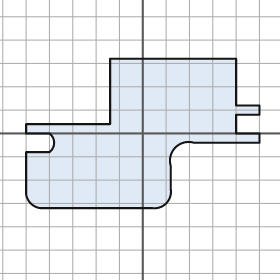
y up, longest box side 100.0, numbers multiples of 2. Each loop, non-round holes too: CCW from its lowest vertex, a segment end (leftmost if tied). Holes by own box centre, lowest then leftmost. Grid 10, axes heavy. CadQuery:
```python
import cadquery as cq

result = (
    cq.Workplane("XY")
    .moveTo(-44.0, -32.0)
    .lineTo(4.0, -32.0)
    .threePointArc((10.0, -30.0), (12.0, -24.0))
    .lineTo(12.0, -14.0)
    .threePointArc((14.0, -6.0), (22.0, -4.0))
    .lineTo(50.0, -4.0)
    .lineTo(50.0, 0.0)
    .lineTo(40.0, 0.0)
    .lineTo(40.0, 8.0)
    .lineTo(50.0, 8.0)
    .lineTo(50.0, 12.0)
    .lineTo(40.0, 12.0)
    .lineTo(40.0, 32.0)
    .lineTo(-14.0, 32.0)
    .lineTo(-14.0, 4.0)
    .lineTo(-50.0, 4.0)
    .lineTo(-50.0, 0.0)
    .lineTo(-40.0, 0.0)
    .threePointArc((-38.0, -4.0), (-40.0, -8.0))
    .lineTo(-50.0, -8.0)
    .lineTo(-50.0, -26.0)
    .threePointArc((-48.0, -30.0), (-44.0, -32.0))
    .close()
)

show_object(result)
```